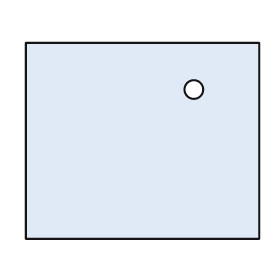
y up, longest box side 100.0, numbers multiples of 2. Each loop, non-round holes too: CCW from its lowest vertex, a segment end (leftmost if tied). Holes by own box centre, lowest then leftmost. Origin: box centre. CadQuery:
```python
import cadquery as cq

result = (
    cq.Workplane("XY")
    .moveTo(-50.0, -42.0)
    .lineTo(50.0, -42.0)
    .lineTo(50.0, 42.0)
    .lineTo(-50.0, 42.0)
    .close()
    .moveTo(22.0, 22.0)
    .circle(4.0)
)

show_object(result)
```